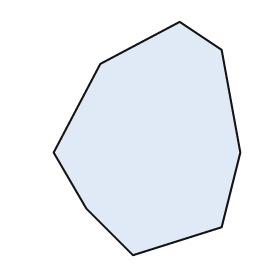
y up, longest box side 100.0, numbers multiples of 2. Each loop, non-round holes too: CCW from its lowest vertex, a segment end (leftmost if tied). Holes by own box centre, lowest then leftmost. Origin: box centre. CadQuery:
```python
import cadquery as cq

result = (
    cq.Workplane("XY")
    .moveTo(-6.0, -50.0)
    .lineTo(32.0, -38.0)
    .lineTo(40.0, -6.0)
    .lineTo(32.0, 38.0)
    .lineTo(14.0, 50.0)
    .lineTo(-20.0, 32.0)
    .lineTo(-40.0, -6.0)
    .lineTo(-26.0, -30.0)
    .close()
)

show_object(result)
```